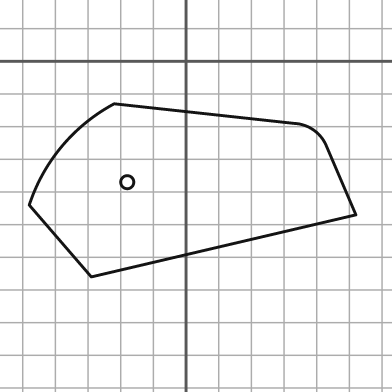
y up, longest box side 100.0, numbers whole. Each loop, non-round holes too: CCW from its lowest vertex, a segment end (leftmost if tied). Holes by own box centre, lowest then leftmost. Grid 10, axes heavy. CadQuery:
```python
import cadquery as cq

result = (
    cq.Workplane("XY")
    .moveTo(-29.0, -66.0)
    .lineTo(52.0, -47.0)
    .lineTo(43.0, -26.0)
    .threePointArc((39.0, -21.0), (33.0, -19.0))
    .lineTo(-22.0, -13.0)
    .threePointArc((-38.0, -26.0), (-48.0, -44.0))
    .close()
    .moveTo(-18.0, -37.0)
    .circle(2.0)
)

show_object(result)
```